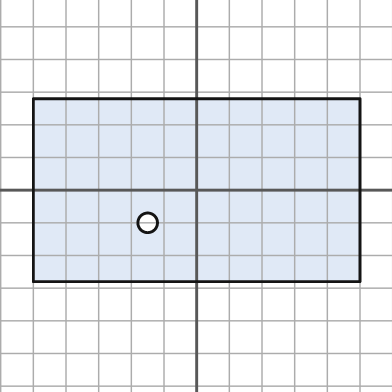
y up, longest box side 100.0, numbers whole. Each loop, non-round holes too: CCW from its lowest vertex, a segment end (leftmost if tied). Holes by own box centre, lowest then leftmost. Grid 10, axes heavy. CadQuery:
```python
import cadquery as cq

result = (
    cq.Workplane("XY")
    .moveTo(-50.0, -28.0)
    .lineTo(50.0, -28.0)
    .lineTo(50.0, 28.0)
    .lineTo(-50.0, 28.0)
    .close()
    .moveTo(-15.0, -10.0)
    .circle(3.0)
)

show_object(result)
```